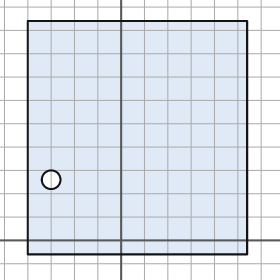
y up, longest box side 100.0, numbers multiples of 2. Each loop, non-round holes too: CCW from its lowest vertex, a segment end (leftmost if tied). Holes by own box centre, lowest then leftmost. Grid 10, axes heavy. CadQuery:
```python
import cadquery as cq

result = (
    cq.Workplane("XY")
    .moveTo(-40.0, -6.0)
    .lineTo(54.0, -6.0)
    .lineTo(54.0, 94.0)
    .lineTo(-40.0, 94.0)
    .close()
    .moveTo(-30.0, 26.0)
    .circle(4.0)
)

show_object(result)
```